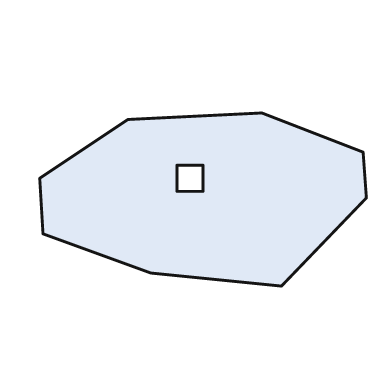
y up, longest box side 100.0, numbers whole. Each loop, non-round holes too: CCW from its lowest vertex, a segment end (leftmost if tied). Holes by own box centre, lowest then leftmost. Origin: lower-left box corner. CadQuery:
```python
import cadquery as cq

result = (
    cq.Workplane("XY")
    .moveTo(74.0, 0.0)
    .lineTo(100.0, 27.0)
    .lineTo(99.0, 41.0)
    .lineTo(68.0, 53.0)
    .lineTo(27.0, 51.0)
    .lineTo(0.0, 33.0)
    .lineTo(1.0, 16.0)
    .lineTo(34.0, 4.0)
    .close()
    .moveTo(42.0, 29.0)
    .lineTo(50.0, 29.0)
    .lineTo(50.0, 37.0)
    .lineTo(42.0, 37.0)
    .close()
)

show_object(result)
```